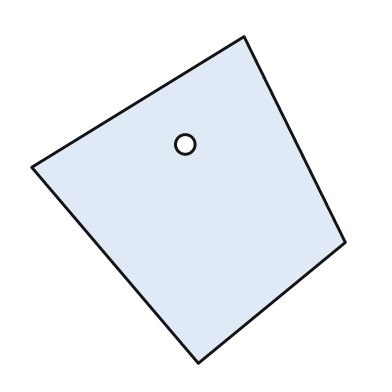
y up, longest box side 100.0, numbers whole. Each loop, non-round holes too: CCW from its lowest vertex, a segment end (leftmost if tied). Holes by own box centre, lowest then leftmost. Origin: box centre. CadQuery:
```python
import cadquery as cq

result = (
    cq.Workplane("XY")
    .moveTo(3.0, -50.0)
    .lineTo(48.0, -13.0)
    .lineTo(17.0, 50.0)
    .lineTo(-48.0, 10.0)
    .close()
    .moveTo(-1.0, 17.0)
    .circle(3.0)
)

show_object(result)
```